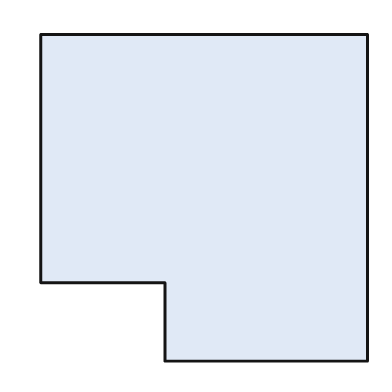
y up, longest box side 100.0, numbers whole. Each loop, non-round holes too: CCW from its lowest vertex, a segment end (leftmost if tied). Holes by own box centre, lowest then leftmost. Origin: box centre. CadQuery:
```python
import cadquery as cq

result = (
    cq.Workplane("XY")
    .moveTo(-12.0, -50.0)
    .lineTo(50.0, -50.0)
    .lineTo(50.0, 50.0)
    .lineTo(-50.0, 50.0)
    .lineTo(-50.0, -26.0)
    .lineTo(-12.0, -26.0)
    .close()
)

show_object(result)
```